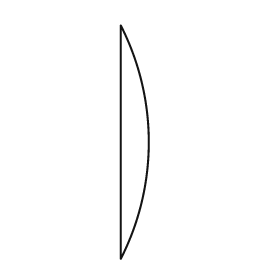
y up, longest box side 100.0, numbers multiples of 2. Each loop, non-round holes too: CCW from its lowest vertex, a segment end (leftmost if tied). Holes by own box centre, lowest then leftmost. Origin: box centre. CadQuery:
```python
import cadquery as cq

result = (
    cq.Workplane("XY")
    .moveTo(-6.0, -50.0)
    .threePointArc((6.0, 0.0), (-6.0, 50.0))
    .close()
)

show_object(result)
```